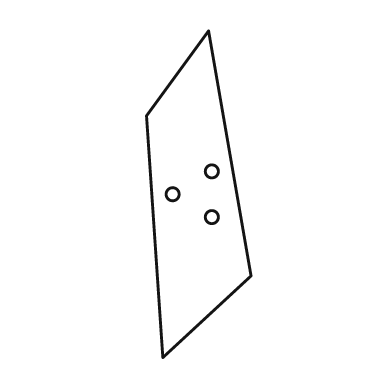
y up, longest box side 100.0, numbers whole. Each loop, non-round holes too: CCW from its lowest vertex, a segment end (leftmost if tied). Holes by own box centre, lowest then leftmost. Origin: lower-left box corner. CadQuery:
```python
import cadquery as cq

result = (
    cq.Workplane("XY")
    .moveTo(5.0, 0.0)
    .lineTo(32.0, 25.0)
    .lineTo(19.0, 100.0)
    .lineTo(0.0, 74.0)
    .close()
    .moveTo(20.0, 43.0)
    .circle(2.0)
    .moveTo(8.0, 50.0)
    .circle(2.0)
    .moveTo(20.0, 57.0)
    .circle(2.0)
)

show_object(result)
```